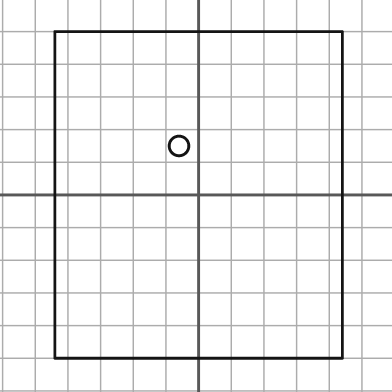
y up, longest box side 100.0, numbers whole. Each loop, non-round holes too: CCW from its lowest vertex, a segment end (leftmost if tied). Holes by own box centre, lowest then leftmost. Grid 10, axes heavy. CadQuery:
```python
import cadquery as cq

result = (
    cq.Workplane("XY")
    .moveTo(-44.0, -50.0)
    .lineTo(44.0, -50.0)
    .lineTo(44.0, 50.0)
    .lineTo(-44.0, 50.0)
    .close()
    .moveTo(-6.0, 15.0)
    .circle(3.0)
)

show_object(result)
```